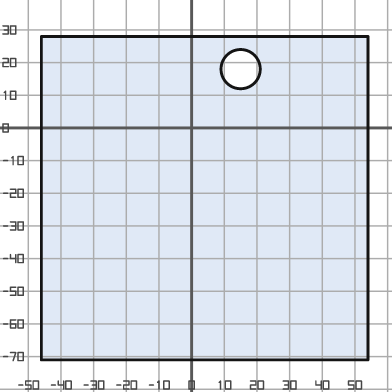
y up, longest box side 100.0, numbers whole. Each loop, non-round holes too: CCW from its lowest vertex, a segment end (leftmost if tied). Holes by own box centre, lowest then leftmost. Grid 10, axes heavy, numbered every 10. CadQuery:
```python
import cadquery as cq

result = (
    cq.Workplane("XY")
    .moveTo(-46.0, -71.0)
    .lineTo(54.0, -71.0)
    .lineTo(54.0, 28.0)
    .lineTo(-46.0, 28.0)
    .close()
    .moveTo(15.0, 18.0)
    .circle(6.0)
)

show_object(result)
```